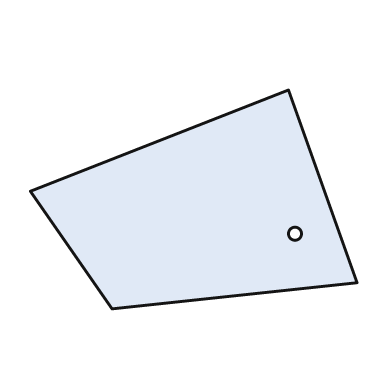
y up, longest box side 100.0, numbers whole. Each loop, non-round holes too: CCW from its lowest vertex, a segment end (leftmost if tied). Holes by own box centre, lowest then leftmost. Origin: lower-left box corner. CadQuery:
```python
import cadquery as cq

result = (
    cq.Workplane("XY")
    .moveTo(25.0, 0.0)
    .lineTo(100.0, 8.0)
    .lineTo(79.0, 67.0)
    .lineTo(0.0, 36.0)
    .close()
    .moveTo(81.0, 23.0)
    .circle(2.0)
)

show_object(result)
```